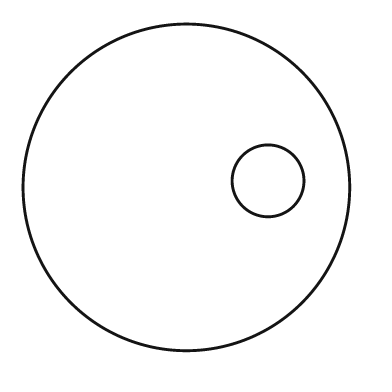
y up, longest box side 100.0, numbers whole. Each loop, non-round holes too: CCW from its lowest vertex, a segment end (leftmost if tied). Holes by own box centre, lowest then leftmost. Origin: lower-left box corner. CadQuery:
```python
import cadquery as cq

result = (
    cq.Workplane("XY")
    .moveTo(50.0, 50.0)
    .circle(50.0)
    .moveTo(75.0, 52.0)
    .circle(11.0)
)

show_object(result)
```